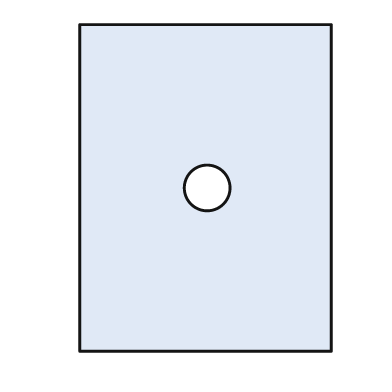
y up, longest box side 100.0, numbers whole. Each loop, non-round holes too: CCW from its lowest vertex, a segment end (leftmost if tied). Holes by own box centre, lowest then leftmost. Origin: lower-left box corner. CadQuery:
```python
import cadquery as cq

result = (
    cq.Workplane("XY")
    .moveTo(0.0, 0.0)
    .lineTo(77.0, 0.0)
    .lineTo(77.0, 100.0)
    .lineTo(0.0, 100.0)
    .close()
    .moveTo(39.0, 50.0)
    .circle(7.0)
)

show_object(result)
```